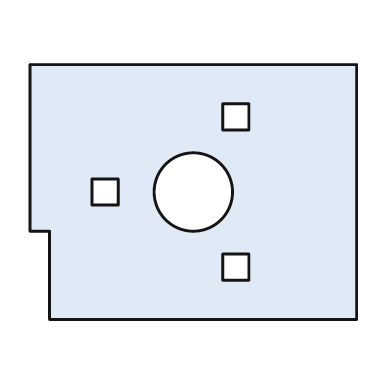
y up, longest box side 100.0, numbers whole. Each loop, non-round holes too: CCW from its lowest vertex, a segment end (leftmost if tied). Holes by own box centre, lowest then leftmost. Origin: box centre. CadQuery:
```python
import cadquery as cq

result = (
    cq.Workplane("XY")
    .moveTo(-44.0, -39.0)
    .lineTo(50.0, -39.0)
    .lineTo(50.0, 39.0)
    .lineTo(-50.0, 39.0)
    .lineTo(-50.0, -12.0)
    .lineTo(-44.0, -12.0)
    .close()
    .moveTo(9.0, -27.0)
    .lineTo(17.0, -27.0)
    .lineTo(17.0, -19.0)
    .lineTo(9.0, -19.0)
    .close()
    .moveTo(-31.0, -4.0)
    .lineTo(-23.0, -4.0)
    .lineTo(-23.0, 4.0)
    .lineTo(-31.0, 4.0)
    .close()
    .moveTo(0.0, 0.0)
    .circle(12.0)
    .moveTo(9.0, 19.0)
    .lineTo(17.0, 19.0)
    .lineTo(17.0, 27.0)
    .lineTo(9.0, 27.0)
    .close()
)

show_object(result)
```